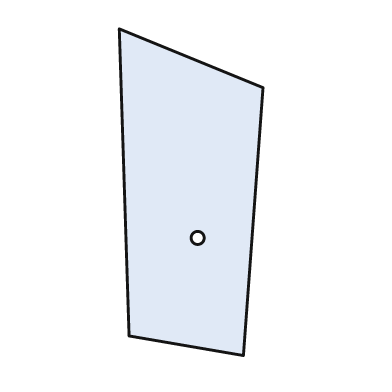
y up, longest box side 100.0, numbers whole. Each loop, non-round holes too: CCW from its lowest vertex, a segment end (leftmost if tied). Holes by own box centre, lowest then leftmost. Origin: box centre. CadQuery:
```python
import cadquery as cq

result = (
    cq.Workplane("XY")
    .moveTo(16.0, -50.0)
    .lineTo(22.0, 32.0)
    .lineTo(-22.0, 50.0)
    .lineTo(-19.0, -44.0)
    .close()
    .moveTo(2.0, -14.0)
    .circle(2.0)
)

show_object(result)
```